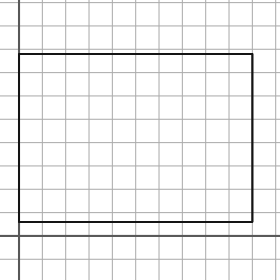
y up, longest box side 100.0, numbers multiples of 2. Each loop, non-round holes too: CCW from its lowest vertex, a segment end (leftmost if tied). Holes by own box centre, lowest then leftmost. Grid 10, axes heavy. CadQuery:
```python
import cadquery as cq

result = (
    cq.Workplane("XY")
    .moveTo(0.0, 6.0)
    .lineTo(100.0, 6.0)
    .lineTo(100.0, 78.0)
    .lineTo(0.0, 78.0)
    .close()
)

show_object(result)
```